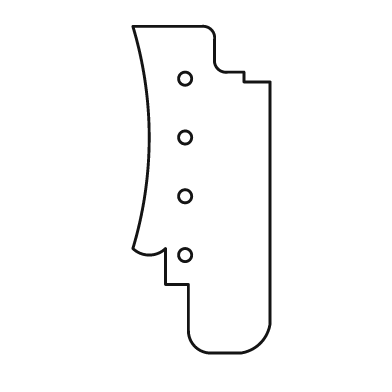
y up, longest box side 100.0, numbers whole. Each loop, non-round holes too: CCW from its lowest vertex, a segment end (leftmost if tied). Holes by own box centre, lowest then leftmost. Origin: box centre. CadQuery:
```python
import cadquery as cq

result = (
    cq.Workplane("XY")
    .moveTo(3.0, -50.0)
    .lineTo(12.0, -50.0)
    .threePointArc((18.0, -47.0), (21.0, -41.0))
    .lineTo(21.0, 33.0)
    .lineTo(13.0, 33.0)
    .lineTo(13.0, 36.0)
    .lineTo(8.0, 36.0)
    .threePointArc((5.0, 37.0), (4.0, 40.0))
    .lineTo(4.0, 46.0)
    .threePointArc((3.0, 49.0), (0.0, 50.0))
    .lineTo(-21.0, 50.0)
    .threePointArc((-16.0, 16.0), (-21.0, -18.0))
    .threePointArc((-16.0, -20.0), (-11.0, -18.0))
    .lineTo(-11.0, -29.0)
    .lineTo(-4.0, -29.0)
    .lineTo(-4.0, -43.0)
    .threePointArc((-2.0, -48.0), (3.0, -50.0))
    .close()
    .moveTo(-5.0, -20.0)
    .circle(2.0)
    .moveTo(-5.0, -2.0)
    .circle(2.0)
    .moveTo(-5.0, 16.0)
    .circle(2.0)
    .moveTo(-5.0, 34.0)
    .circle(2.0)
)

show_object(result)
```